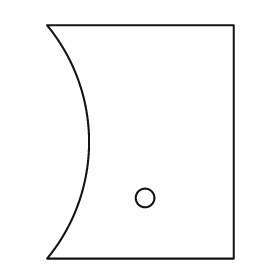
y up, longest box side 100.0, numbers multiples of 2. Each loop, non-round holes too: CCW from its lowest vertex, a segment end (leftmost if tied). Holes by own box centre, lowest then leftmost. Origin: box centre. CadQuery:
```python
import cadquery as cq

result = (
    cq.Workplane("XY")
    .moveTo(-40.0, -50.0)
    .lineTo(40.0, -50.0)
    .lineTo(40.0, 50.0)
    .lineTo(-40.0, 50.0)
    .threePointArc((-22.0, 0.0), (-40.0, -50.0))
    .close()
    .moveTo(2.0, -24.0)
    .circle(4.0)
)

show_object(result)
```